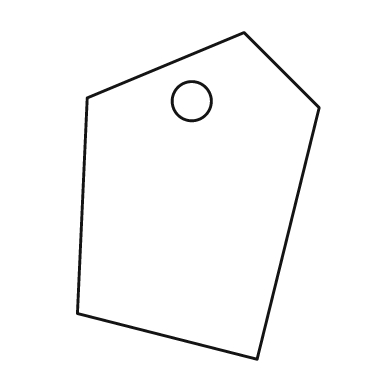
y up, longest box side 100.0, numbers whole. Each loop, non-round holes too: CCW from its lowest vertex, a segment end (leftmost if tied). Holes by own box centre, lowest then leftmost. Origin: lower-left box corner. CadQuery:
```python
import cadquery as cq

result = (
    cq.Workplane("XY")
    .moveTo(55.0, 0.0)
    .lineTo(74.0, 77.0)
    .lineTo(51.0, 100.0)
    .lineTo(3.0, 80.0)
    .lineTo(0.0, 14.0)
    .close()
    .moveTo(35.0, 79.0)
    .circle(6.0)
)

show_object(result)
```